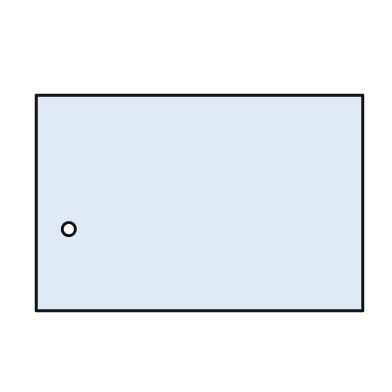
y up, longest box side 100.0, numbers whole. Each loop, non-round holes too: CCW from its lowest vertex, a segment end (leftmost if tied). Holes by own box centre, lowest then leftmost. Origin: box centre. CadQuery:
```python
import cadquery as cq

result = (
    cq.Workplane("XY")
    .moveTo(-50.0, -33.0)
    .lineTo(50.0, -33.0)
    .lineTo(50.0, 33.0)
    .lineTo(-50.0, 33.0)
    .close()
    .moveTo(-40.0, -8.0)
    .circle(2.0)
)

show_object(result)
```